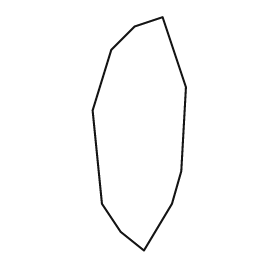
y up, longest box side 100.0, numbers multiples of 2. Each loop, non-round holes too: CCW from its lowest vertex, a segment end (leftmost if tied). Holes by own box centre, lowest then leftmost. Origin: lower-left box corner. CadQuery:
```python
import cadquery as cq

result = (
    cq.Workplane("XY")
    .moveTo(22.0, 0.0)
    .lineTo(34.0, 20.0)
    .lineTo(38.0, 34.0)
    .lineTo(40.0, 70.0)
    .lineTo(30.0, 100.0)
    .lineTo(18.0, 96.0)
    .lineTo(8.0, 86.0)
    .lineTo(0.0, 60.0)
    .lineTo(4.0, 20.0)
    .lineTo(12.0, 8.0)
    .close()
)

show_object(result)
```